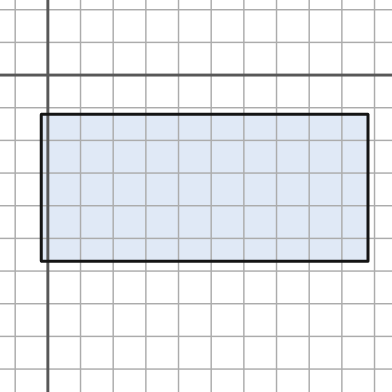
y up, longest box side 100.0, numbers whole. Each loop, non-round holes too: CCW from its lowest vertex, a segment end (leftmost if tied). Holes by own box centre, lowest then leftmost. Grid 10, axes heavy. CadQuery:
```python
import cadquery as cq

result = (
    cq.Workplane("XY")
    .moveTo(-2.0, -57.0)
    .lineTo(98.0, -57.0)
    .lineTo(98.0, -12.0)
    .lineTo(-2.0, -12.0)
    .close()
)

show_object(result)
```